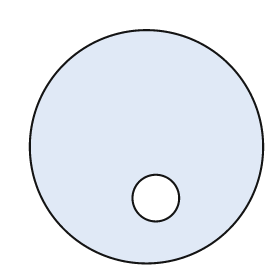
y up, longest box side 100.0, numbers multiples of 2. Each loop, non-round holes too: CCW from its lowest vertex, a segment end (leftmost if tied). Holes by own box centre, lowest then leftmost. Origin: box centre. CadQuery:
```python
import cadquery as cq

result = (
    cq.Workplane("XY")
    .moveTo(0.0, 0.0)
    .circle(50.0)
    .moveTo(4.0, -22.0)
    .circle(10.0)
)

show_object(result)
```